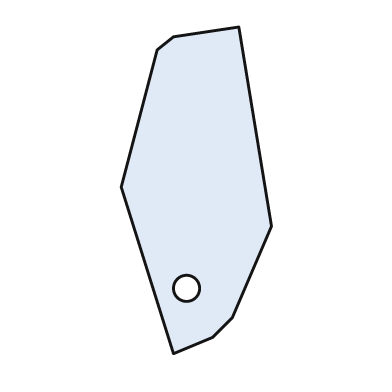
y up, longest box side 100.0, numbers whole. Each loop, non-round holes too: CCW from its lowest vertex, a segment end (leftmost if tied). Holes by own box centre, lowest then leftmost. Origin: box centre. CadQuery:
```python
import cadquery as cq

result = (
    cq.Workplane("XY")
    .moveTo(-7.0, -50.0)
    .lineTo(5.0, -45.0)
    .lineTo(11.0, -39.0)
    .lineTo(23.0, -11.0)
    .lineTo(13.0, 50.0)
    .lineTo(-7.0, 47.0)
    .lineTo(-12.0, 43.0)
    .lineTo(-23.0, 1.0)
    .close()
    .moveTo(-3.0, -30.0)
    .circle(4.0)
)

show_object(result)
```